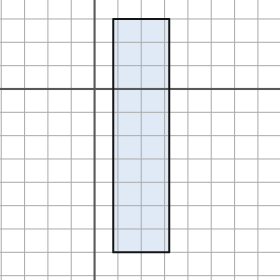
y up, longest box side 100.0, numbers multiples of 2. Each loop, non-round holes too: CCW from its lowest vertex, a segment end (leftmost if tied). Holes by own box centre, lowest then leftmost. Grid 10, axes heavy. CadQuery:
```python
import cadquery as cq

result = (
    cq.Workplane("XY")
    .moveTo(8.0, -70.0)
    .lineTo(32.0, -70.0)
    .lineTo(32.0, 30.0)
    .lineTo(8.0, 30.0)
    .close()
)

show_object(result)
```